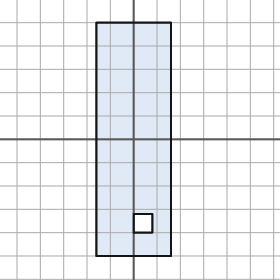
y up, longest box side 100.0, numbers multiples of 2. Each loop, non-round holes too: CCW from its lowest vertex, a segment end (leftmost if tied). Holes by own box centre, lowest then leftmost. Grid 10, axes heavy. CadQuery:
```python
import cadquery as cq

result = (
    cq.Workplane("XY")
    .moveTo(-16.0, -50.0)
    .lineTo(16.0, -50.0)
    .lineTo(16.0, 50.0)
    .lineTo(-16.0, 50.0)
    .close()
    .moveTo(0.0, -40.0)
    .lineTo(8.0, -40.0)
    .lineTo(8.0, -32.0)
    .lineTo(0.0, -32.0)
    .close()
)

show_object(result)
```